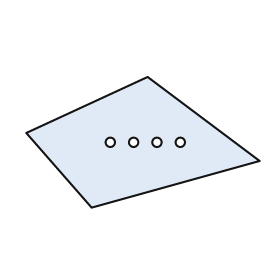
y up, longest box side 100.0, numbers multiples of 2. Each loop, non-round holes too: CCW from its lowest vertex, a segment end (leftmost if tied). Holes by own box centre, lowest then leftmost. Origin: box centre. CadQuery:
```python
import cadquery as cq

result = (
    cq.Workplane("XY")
    .moveTo(-22.0, -28.0)
    .lineTo(50.0, -8.0)
    .lineTo(2.0, 28.0)
    .lineTo(-50.0, 4.0)
    .close()
    .moveTo(-14.0, 0.0)
    .circle(2.0)
    .moveTo(-4.0, 0.0)
    .circle(2.0)
    .moveTo(6.0, 0.0)
    .circle(2.0)
    .moveTo(16.0, 0.0)
    .circle(2.0)
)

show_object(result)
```